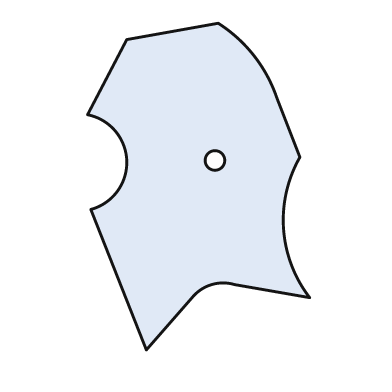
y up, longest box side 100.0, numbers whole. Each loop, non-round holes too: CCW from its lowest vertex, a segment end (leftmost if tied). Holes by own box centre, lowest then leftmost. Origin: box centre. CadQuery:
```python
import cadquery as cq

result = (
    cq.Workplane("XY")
    .moveTo(-16.0, -50.0)
    .lineTo(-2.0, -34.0)
    .threePointArc((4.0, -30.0), (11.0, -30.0))
    .lineTo(34.0, -34.0)
    .threePointArc((26.0, -13.0), (31.0, 9.0))
    .lineTo(24.0, 27.0)
    .threePointArc((17.0, 40.0), (6.0, 50.0))
    .lineTo(-22.0, 45.0)
    .lineTo(-34.0, 22.0)
    .threePointArc((-22.0, 8.0), (-33.0, -7.0))
    .close()
    .moveTo(5.0, 8.0)
    .circle(3.0)
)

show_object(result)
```